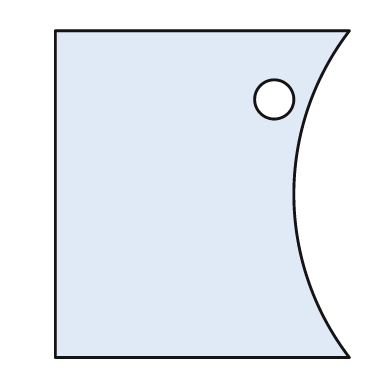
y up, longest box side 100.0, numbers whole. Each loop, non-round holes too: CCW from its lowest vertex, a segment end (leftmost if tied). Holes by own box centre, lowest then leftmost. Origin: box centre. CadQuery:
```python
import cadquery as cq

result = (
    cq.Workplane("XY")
    .moveTo(-45.0, -50.0)
    .lineTo(45.0, -50.0)
    .threePointArc((28.0, 0.0), (45.0, 50.0))
    .lineTo(-45.0, 50.0)
    .close()
    .moveTo(22.0, 29.0)
    .circle(6.0)
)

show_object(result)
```